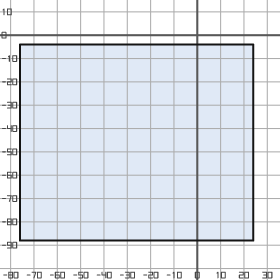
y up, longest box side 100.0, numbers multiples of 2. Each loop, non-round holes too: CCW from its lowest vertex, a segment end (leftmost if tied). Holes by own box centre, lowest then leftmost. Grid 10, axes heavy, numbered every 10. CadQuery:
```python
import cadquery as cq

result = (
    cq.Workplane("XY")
    .moveTo(-76.0, -88.0)
    .lineTo(24.0, -88.0)
    .lineTo(24.0, -4.0)
    .lineTo(-76.0, -4.0)
    .close()
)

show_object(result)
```